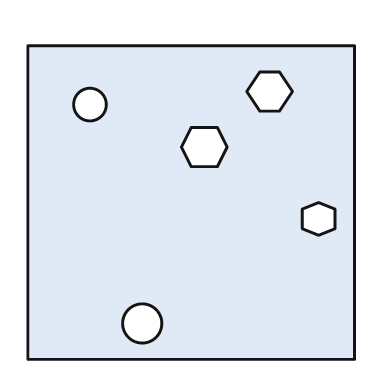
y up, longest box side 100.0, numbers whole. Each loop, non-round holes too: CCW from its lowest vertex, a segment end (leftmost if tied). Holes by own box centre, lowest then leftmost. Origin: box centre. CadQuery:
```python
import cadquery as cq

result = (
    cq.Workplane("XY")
    .moveTo(-50.0, -48.0)
    .lineTo(50.0, -48.0)
    .lineTo(50.0, 48.0)
    .lineTo(-50.0, 48.0)
    .close()
    .moveTo(-15.0, -37.0)
    .circle(6.0)
    .moveTo(39.0, -10.0)
    .lineTo(44.0, -8.0)
    .lineTo(44.0, -2.0)
    .lineTo(39.0, 0.0)
    .lineTo(34.0, -2.0)
    .lineTo(34.0, -8.0)
    .close()
    .moveTo(0.0, 11.0)
    .lineTo(8.0, 11.0)
    .lineTo(11.0, 17.0)
    .lineTo(8.0, 23.0)
    .lineTo(0.0, 23.0)
    .lineTo(-3.0, 17.0)
    .close()
    .moveTo(-31.0, 30.0)
    .circle(5.0)
    .moveTo(21.0, 28.0)
    .lineTo(27.0, 28.0)
    .lineTo(31.0, 34.0)
    .lineTo(27.0, 40.0)
    .lineTo(21.0, 40.0)
    .lineTo(17.0, 34.0)
    .close()
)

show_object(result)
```